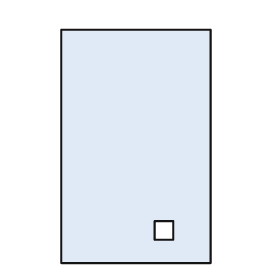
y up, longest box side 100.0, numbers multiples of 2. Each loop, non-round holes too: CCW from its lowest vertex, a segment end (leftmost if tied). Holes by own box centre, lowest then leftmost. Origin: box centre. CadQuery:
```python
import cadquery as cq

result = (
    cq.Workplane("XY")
    .moveTo(-32.0, -50.0)
    .lineTo(32.0, -50.0)
    .lineTo(32.0, 50.0)
    .lineTo(-32.0, 50.0)
    .close()
    .moveTo(8.0, -40.0)
    .lineTo(16.0, -40.0)
    .lineTo(16.0, -32.0)
    .lineTo(8.0, -32.0)
    .close()
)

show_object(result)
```